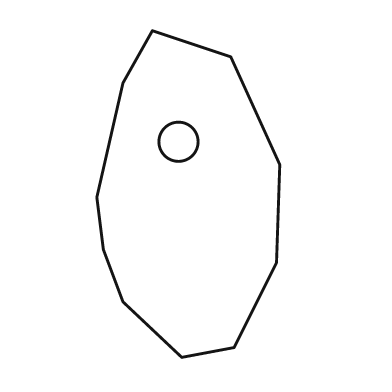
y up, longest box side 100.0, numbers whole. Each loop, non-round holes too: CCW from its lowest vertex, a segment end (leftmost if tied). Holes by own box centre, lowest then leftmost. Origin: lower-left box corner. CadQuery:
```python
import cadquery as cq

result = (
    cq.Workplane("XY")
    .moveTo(26.0, 0.0)
    .lineTo(42.0, 3.0)
    .lineTo(55.0, 29.0)
    .lineTo(56.0, 59.0)
    .lineTo(41.0, 92.0)
    .lineTo(17.0, 100.0)
    .lineTo(8.0, 84.0)
    .lineTo(0.0, 49.0)
    .lineTo(2.0, 33.0)
    .lineTo(8.0, 17.0)
    .close()
    .moveTo(25.0, 66.0)
    .circle(6.0)
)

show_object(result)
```